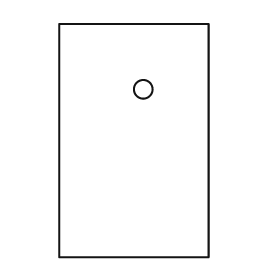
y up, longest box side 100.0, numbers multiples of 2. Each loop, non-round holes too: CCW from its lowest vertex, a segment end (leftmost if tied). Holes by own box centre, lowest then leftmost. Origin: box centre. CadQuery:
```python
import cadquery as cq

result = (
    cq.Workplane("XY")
    .moveTo(-32.0, -50.0)
    .lineTo(32.0, -50.0)
    .lineTo(32.0, 50.0)
    .lineTo(-32.0, 50.0)
    .close()
    .moveTo(4.0, 22.0)
    .circle(4.0)
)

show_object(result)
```